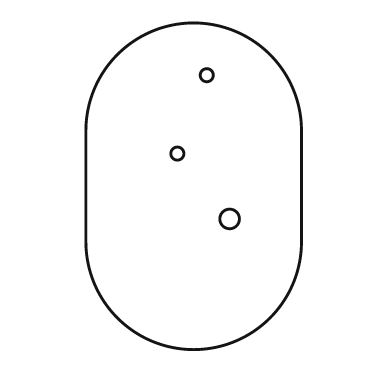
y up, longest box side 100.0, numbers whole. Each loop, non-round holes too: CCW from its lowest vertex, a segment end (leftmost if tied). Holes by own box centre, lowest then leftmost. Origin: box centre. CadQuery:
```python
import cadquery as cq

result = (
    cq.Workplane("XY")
    .moveTo(-33.0, -17.0)
    .threePointArc((0.0, -50.0), (33.0, -17.0))
    .lineTo(33.0, 17.0)
    .threePointArc((0.0, 50.0), (-33.0, 17.0))
    .close()
    .moveTo(11.0, -10.0)
    .circle(3.0)
    .moveTo(-5.0, 10.0)
    .circle(2.0)
    .moveTo(4.0, 34.0)
    .circle(2.0)
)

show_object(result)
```